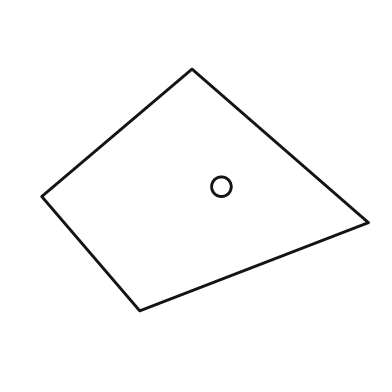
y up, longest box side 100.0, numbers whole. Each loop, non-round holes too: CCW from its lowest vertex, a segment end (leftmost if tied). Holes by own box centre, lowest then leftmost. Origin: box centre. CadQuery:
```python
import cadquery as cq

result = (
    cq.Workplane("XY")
    .moveTo(-20.0, -37.0)
    .lineTo(50.0, -10.0)
    .lineTo(-4.0, 37.0)
    .lineTo(-50.0, -2.0)
    .close()
    .moveTo(5.0, 1.0)
    .circle(3.0)
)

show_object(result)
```